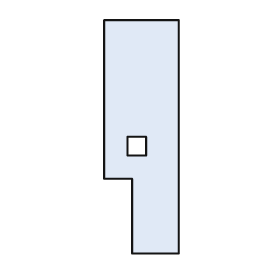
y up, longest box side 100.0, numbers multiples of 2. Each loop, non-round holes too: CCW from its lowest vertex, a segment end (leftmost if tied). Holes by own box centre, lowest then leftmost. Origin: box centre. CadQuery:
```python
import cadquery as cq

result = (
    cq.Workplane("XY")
    .moveTo(-4.0, -50.0)
    .lineTo(16.0, -50.0)
    .lineTo(16.0, 50.0)
    .lineTo(-16.0, 50.0)
    .lineTo(-16.0, -18.0)
    .lineTo(-4.0, -18.0)
    .close()
    .moveTo(-6.0, -8.0)
    .lineTo(2.0, -8.0)
    .lineTo(2.0, 0.0)
    .lineTo(-6.0, 0.0)
    .close()
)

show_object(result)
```